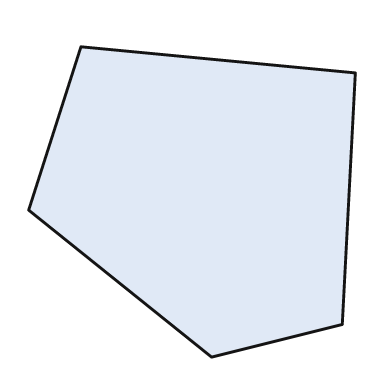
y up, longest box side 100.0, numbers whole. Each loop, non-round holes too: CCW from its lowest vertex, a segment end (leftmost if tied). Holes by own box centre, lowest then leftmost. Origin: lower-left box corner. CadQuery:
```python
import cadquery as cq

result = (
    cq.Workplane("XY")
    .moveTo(56.0, 0.0)
    .lineTo(96.0, 10.0)
    .lineTo(100.0, 87.0)
    .lineTo(16.0, 95.0)
    .lineTo(0.0, 45.0)
    .close()
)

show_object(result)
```